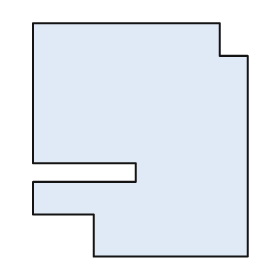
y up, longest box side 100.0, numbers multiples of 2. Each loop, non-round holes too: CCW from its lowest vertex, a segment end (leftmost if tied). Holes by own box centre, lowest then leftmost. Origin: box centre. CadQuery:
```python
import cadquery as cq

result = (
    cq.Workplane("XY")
    .moveTo(-20.0, -50.0)
    .lineTo(46.0, -50.0)
    .lineTo(46.0, 36.0)
    .lineTo(34.0, 36.0)
    .lineTo(34.0, 50.0)
    .lineTo(-46.0, 50.0)
    .lineTo(-46.0, -10.0)
    .lineTo(-2.0, -10.0)
    .lineTo(-2.0, -18.0)
    .lineTo(-46.0, -18.0)
    .lineTo(-46.0, -32.0)
    .lineTo(-20.0, -32.0)
    .close()
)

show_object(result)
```